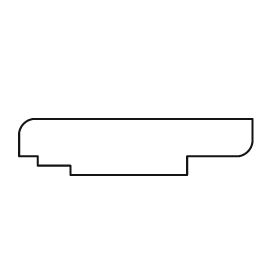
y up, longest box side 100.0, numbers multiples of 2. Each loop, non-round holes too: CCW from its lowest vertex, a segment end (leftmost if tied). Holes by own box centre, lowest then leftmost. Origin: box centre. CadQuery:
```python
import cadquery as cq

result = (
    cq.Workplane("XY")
    .moveTo(-28.0, -12.0)
    .lineTo(22.0, -12.0)
    .lineTo(22.0, -4.0)
    .lineTo(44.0, -4.0)
    .threePointArc((48.0, -2.0), (50.0, 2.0))
    .lineTo(50.0, 12.0)
    .lineTo(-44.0, 12.0)
    .threePointArc((-48.0, 10.0), (-50.0, 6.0))
    .lineTo(-50.0, -4.0)
    .lineTo(-42.0, -4.0)
    .lineTo(-42.0, -8.0)
    .lineTo(-28.0, -8.0)
    .close()
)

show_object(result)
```